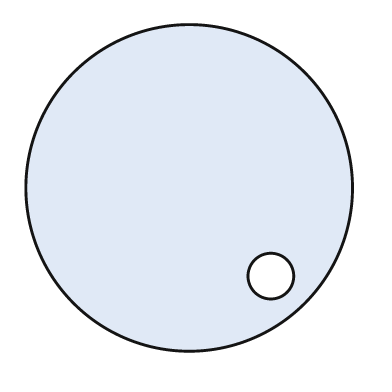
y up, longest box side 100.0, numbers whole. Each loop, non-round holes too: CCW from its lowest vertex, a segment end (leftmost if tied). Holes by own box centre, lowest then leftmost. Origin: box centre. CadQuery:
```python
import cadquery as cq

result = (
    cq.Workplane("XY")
    .moveTo(0.0, 0.0)
    .circle(50.0)
    .moveTo(25.0, -27.0)
    .circle(7.0)
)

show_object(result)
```